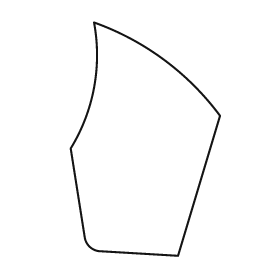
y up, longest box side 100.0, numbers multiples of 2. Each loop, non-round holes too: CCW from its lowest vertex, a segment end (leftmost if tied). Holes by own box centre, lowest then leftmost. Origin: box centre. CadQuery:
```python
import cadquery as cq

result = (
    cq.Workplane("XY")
    .moveTo(14.0, -50.0)
    .lineTo(32.0, 10.0)
    .threePointArc((8.0, 34.0), (-22.0, 50.0))
    .threePointArc((-22.0, 22.0), (-32.0, -4.0))
    .lineTo(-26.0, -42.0)
    .threePointArc((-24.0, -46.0), (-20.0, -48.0))
    .close()
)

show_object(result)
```